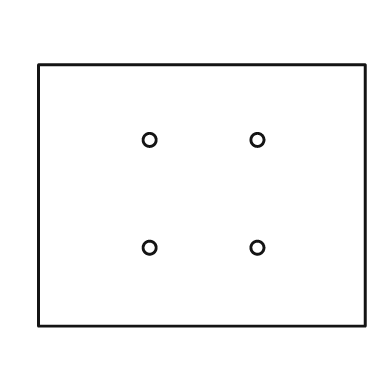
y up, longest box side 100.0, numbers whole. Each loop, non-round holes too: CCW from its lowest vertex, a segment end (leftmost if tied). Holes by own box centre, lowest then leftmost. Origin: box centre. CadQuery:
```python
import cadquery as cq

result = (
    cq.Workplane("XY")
    .moveTo(-50.0, -40.0)
    .lineTo(50.0, -40.0)
    .lineTo(50.0, 40.0)
    .lineTo(-50.0, 40.0)
    .close()
    .moveTo(-16.0, -16.0)
    .circle(2.0)
    .moveTo(17.0, -16.0)
    .circle(2.0)
    .moveTo(-16.0, 17.0)
    .circle(2.0)
    .moveTo(17.0, 17.0)
    .circle(2.0)
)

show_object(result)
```